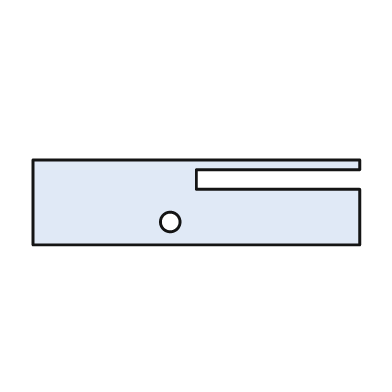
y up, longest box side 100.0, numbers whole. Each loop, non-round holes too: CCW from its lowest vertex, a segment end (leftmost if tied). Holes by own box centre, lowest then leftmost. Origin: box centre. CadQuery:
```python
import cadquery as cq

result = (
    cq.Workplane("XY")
    .moveTo(-50.0, -13.0)
    .lineTo(50.0, -13.0)
    .lineTo(50.0, 4.0)
    .lineTo(0.0, 4.0)
    .lineTo(0.0, 10.0)
    .lineTo(50.0, 10.0)
    .lineTo(50.0, 13.0)
    .lineTo(-50.0, 13.0)
    .close()
    .moveTo(-8.0, -6.0)
    .circle(3.0)
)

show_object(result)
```